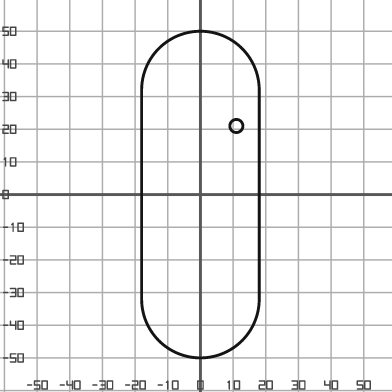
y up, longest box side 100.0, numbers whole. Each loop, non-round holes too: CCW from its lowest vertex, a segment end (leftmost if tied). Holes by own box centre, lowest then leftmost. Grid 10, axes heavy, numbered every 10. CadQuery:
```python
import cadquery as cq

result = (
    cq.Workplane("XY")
    .moveTo(-18.0, -32.0)
    .threePointArc((0.0, -50.0), (18.0, -32.0))
    .lineTo(18.0, 32.0)
    .threePointArc((0.0, 50.0), (-18.0, 32.0))
    .close()
    .moveTo(11.0, 21.0)
    .circle(2.0)
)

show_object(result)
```